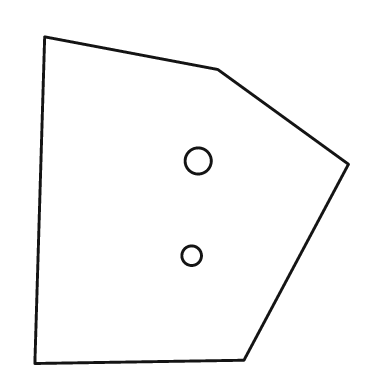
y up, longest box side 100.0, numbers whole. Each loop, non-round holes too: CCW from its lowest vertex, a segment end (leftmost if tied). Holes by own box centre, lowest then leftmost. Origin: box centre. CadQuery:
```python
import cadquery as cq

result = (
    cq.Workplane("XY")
    .moveTo(-48.0, -50.0)
    .lineTo(16.0, -49.0)
    .lineTo(48.0, 11.0)
    .lineTo(8.0, 40.0)
    .lineTo(-45.0, 50.0)
    .close()
    .moveTo(0.0, -17.0)
    .circle(3.0)
    .moveTo(2.0, 12.0)
    .circle(4.0)
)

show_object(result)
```